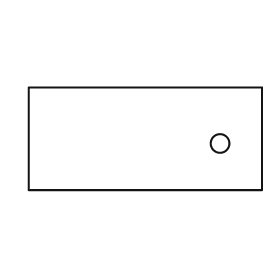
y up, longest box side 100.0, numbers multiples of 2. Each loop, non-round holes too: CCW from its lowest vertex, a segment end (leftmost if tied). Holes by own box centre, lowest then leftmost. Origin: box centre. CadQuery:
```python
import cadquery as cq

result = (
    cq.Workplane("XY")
    .moveTo(-50.0, -22.0)
    .lineTo(50.0, -22.0)
    .lineTo(50.0, 22.0)
    .lineTo(-50.0, 22.0)
    .close()
    .moveTo(32.0, -2.0)
    .circle(4.0)
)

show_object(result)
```